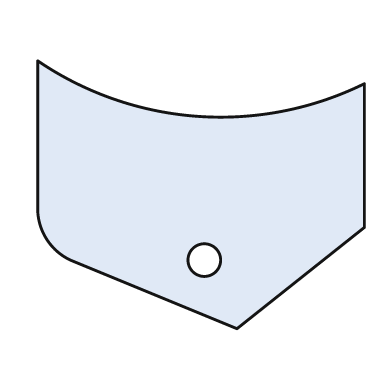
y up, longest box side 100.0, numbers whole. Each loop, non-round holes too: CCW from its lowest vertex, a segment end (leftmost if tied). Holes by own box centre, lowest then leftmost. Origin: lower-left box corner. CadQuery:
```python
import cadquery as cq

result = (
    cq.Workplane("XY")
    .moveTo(61.0, 0.0)
    .lineTo(100.0, 31.0)
    .lineTo(100.0, 75.0)
    .threePointArc((49.0, 65.0), (0.0, 82.0))
    .lineTo(0.0, 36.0)
    .threePointArc((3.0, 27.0), (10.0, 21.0))
    .close()
    .moveTo(51.0, 21.0)
    .circle(5.0)
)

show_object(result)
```